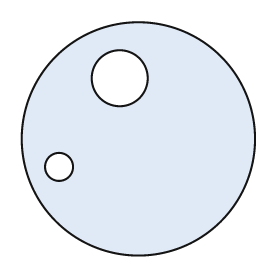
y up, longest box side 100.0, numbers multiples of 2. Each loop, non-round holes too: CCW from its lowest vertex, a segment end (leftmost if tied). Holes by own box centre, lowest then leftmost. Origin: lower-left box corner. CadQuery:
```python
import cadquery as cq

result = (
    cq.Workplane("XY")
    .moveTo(50.0, 50.0)
    .circle(50.0)
    .moveTo(16.0, 38.0)
    .circle(6.0)
    .moveTo(42.0, 76.0)
    .circle(12.0)
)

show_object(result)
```